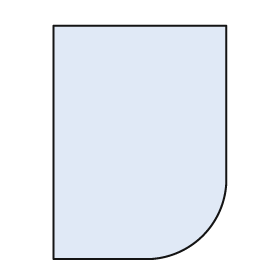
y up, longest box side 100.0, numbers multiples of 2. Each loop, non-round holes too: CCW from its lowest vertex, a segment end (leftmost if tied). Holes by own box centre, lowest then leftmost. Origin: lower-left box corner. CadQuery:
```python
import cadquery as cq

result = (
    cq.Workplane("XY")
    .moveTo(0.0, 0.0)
    .lineTo(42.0, 0.0)
    .threePointArc((64.0, 10.0), (74.0, 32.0))
    .lineTo(74.0, 100.0)
    .lineTo(0.0, 100.0)
    .close()
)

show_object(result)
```